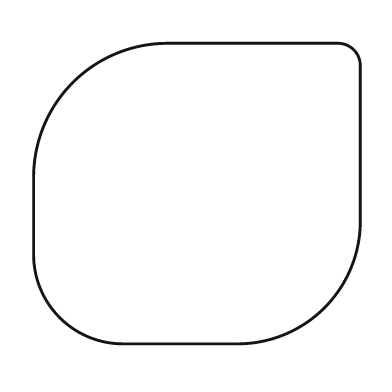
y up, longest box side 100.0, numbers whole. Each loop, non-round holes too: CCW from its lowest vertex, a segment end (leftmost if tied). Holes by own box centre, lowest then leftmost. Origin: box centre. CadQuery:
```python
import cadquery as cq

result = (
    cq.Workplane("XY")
    .moveTo(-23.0, -46.0)
    .lineTo(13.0, -46.0)
    .threePointArc((39.0, -35.0), (50.0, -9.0))
    .lineTo(50.0, 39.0)
    .threePointArc((48.0, 44.0), (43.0, 46.0))
    .lineTo(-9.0, 46.0)
    .threePointArc((-38.0, 34.0), (-50.0, 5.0))
    .lineTo(-50.0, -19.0)
    .threePointArc((-42.0, -38.0), (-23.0, -46.0))
    .close()
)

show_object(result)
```